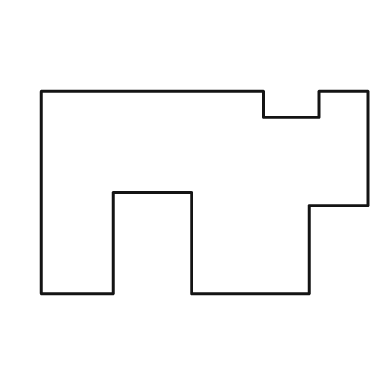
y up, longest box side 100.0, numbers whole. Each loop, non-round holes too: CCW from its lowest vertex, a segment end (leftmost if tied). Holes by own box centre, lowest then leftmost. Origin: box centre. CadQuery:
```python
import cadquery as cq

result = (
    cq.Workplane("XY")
    .moveTo(-50.0, -31.0)
    .lineTo(-28.0, -31.0)
    .lineTo(-28.0, 0.0)
    .lineTo(-4.0, 0.0)
    .lineTo(-4.0, -31.0)
    .lineTo(32.0, -31.0)
    .lineTo(32.0, -4.0)
    .lineTo(50.0, -4.0)
    .lineTo(50.0, 31.0)
    .lineTo(35.0, 31.0)
    .lineTo(35.0, 23.0)
    .lineTo(18.0, 23.0)
    .lineTo(18.0, 31.0)
    .lineTo(-50.0, 31.0)
    .close()
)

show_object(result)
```